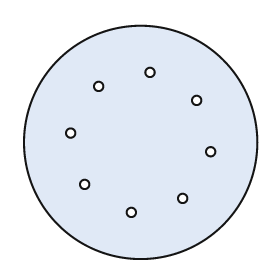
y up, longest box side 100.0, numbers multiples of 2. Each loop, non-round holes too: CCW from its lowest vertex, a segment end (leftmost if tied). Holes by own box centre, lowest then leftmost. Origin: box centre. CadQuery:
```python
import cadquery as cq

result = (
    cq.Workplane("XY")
    .moveTo(0.0, 0.0)
    .circle(50.0)
    .moveTo(-4.0, -30.0)
    .circle(2.0)
    .moveTo(18.0, -24.0)
    .circle(2.0)
    .moveTo(-24.0, -18.0)
    .circle(2.0)
    .moveTo(30.0, -4.0)
    .circle(2.0)
    .moveTo(-30.0, 4.0)
    .circle(2.0)
    .moveTo(24.0, 18.0)
    .circle(2.0)
    .moveTo(-18.0, 24.0)
    .circle(2.0)
    .moveTo(4.0, 30.0)
    .circle(2.0)
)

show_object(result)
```